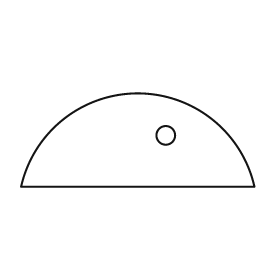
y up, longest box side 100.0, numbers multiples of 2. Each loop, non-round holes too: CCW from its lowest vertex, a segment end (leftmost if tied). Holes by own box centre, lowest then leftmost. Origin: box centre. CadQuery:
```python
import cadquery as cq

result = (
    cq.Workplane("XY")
    .moveTo(-50.0, -20.0)
    .lineTo(50.0, -20.0)
    .threePointArc((0.0, 20.0), (-50.0, -20.0))
    .close()
    .moveTo(12.0, 2.0)
    .circle(4.0)
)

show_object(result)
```